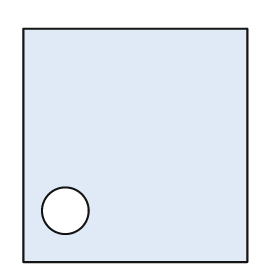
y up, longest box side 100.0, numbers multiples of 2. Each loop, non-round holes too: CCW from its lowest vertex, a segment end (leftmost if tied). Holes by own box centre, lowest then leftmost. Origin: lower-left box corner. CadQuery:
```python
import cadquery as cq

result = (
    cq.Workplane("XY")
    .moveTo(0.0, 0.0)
    .lineTo(96.0, 0.0)
    .lineTo(96.0, 100.0)
    .lineTo(0.0, 100.0)
    .close()
    .moveTo(18.0, 22.0)
    .circle(10.0)
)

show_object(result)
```